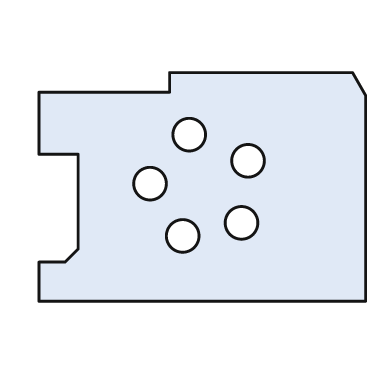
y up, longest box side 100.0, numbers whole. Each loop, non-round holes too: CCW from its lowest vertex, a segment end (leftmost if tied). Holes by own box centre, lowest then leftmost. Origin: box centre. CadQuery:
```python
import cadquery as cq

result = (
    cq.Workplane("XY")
    .moveTo(-50.0, -35.0)
    .lineTo(50.0, -35.0)
    .lineTo(50.0, 28.0)
    .lineTo(46.0, 35.0)
    .lineTo(-10.0, 35.0)
    .lineTo(-10.0, 29.0)
    .lineTo(-50.0, 29.0)
    .lineTo(-50.0, 10.0)
    .lineTo(-38.0, 10.0)
    .lineTo(-38.0, -19.0)
    .lineTo(-42.0, -23.0)
    .lineTo(-50.0, -23.0)
    .close()
    .moveTo(-6.0, -15.0)
    .circle(5.0)
    .moveTo(12.0, -11.0)
    .circle(5.0)
    .moveTo(-16.0, 1.0)
    .circle(5.0)
    .moveTo(14.0, 8.0)
    .circle(5.0)
    .moveTo(-4.0, 16.0)
    .circle(5.0)
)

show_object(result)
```